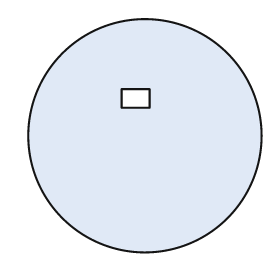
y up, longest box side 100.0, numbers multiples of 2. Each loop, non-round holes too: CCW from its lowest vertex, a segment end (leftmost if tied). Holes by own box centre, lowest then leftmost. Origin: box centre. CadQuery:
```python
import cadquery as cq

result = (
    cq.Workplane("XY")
    .moveTo(0.0, 0.0)
    .circle(50.0)
    .moveTo(-10.0, 12.0)
    .lineTo(2.0, 12.0)
    .lineTo(2.0, 20.0)
    .lineTo(-10.0, 20.0)
    .close()
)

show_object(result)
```